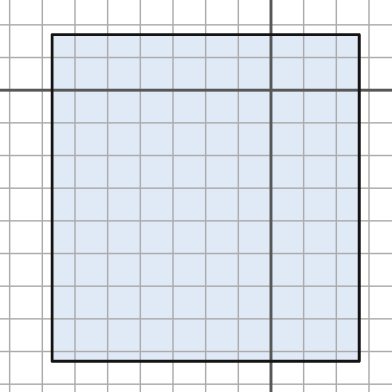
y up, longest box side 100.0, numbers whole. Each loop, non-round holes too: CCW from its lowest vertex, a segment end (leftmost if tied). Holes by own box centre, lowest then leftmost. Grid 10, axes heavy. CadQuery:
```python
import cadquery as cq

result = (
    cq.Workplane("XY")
    .moveTo(-67.0, -83.0)
    .lineTo(27.0, -83.0)
    .lineTo(27.0, 17.0)
    .lineTo(-67.0, 17.0)
    .close()
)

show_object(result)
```